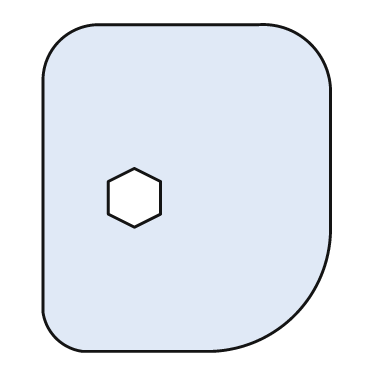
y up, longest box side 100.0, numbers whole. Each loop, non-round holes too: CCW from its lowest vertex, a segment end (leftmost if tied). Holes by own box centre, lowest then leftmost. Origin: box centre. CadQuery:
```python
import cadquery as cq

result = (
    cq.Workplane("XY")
    .moveTo(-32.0, -50.0)
    .lineTo(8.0, -50.0)
    .threePointArc((33.0, -39.0), (44.0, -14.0))
    .lineTo(44.0, 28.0)
    .threePointArc((38.0, 44.0), (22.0, 50.0))
    .lineTo(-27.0, 50.0)
    .threePointArc((-39.0, 45.0), (-44.0, 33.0))
    .lineTo(-44.0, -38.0)
    .threePointArc((-40.0, -46.0), (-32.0, -50.0))
    .close()
    .moveTo(-16.0, -12.0)
    .lineTo(-8.0, -8.0)
    .lineTo(-8.0, 2.0)
    .lineTo(-16.0, 6.0)
    .lineTo(-24.0, 2.0)
    .lineTo(-24.0, -8.0)
    .close()
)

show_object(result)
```